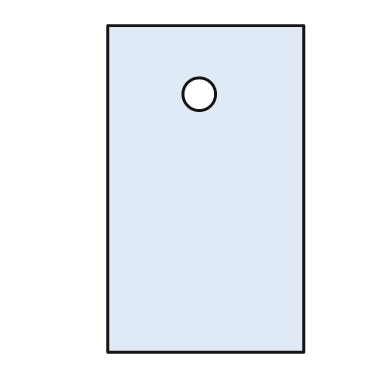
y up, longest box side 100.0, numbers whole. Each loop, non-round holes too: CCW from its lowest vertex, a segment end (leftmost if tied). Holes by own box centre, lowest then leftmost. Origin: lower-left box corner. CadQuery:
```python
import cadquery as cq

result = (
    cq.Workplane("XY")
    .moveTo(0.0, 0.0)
    .lineTo(60.0, 0.0)
    .lineTo(60.0, 100.0)
    .lineTo(0.0, 100.0)
    .close()
    .moveTo(28.0, 79.0)
    .circle(5.0)
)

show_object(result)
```